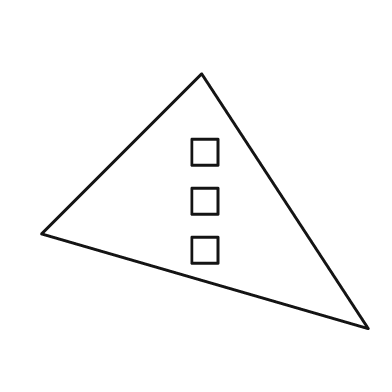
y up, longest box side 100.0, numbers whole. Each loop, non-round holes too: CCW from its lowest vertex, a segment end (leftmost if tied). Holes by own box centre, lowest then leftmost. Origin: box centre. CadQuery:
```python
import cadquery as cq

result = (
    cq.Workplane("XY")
    .moveTo(50.0, -39.0)
    .lineTo(-1.0, 39.0)
    .lineTo(-50.0, -10.0)
    .close()
    .moveTo(-4.0, -19.0)
    .lineTo(4.0, -19.0)
    .lineTo(4.0, -11.0)
    .lineTo(-4.0, -11.0)
    .close()
    .moveTo(-4.0, -4.0)
    .lineTo(4.0, -4.0)
    .lineTo(4.0, 4.0)
    .lineTo(-4.0, 4.0)
    .close()
    .moveTo(-4.0, 11.0)
    .lineTo(4.0, 11.0)
    .lineTo(4.0, 19.0)
    .lineTo(-4.0, 19.0)
    .close()
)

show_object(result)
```